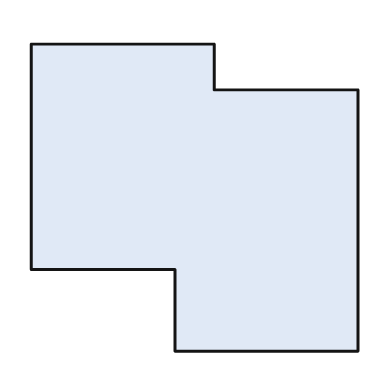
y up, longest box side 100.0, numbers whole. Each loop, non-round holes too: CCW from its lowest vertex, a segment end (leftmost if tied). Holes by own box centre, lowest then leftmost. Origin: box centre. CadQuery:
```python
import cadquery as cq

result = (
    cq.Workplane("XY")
    .moveTo(-6.0, -47.0)
    .lineTo(50.0, -47.0)
    .lineTo(50.0, 33.0)
    .lineTo(6.0, 33.0)
    .lineTo(6.0, 47.0)
    .lineTo(-50.0, 47.0)
    .lineTo(-50.0, -22.0)
    .lineTo(-6.0, -22.0)
    .close()
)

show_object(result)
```